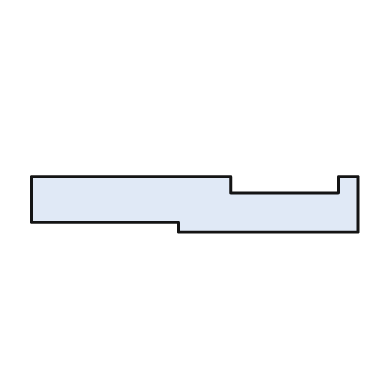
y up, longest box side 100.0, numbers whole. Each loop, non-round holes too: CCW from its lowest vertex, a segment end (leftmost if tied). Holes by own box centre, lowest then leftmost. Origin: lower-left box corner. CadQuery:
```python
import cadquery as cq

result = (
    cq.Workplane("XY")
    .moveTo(45.0, 0.0)
    .lineTo(100.0, 0.0)
    .lineTo(100.0, 17.0)
    .lineTo(94.0, 17.0)
    .lineTo(94.0, 12.0)
    .lineTo(61.0, 12.0)
    .lineTo(61.0, 17.0)
    .lineTo(0.0, 17.0)
    .lineTo(0.0, 3.0)
    .lineTo(45.0, 3.0)
    .close()
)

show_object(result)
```